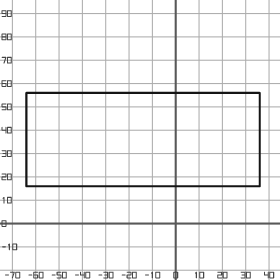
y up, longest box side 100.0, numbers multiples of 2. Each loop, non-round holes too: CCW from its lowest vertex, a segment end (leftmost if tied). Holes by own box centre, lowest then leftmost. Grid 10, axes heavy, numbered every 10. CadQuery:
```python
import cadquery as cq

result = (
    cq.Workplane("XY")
    .moveTo(-64.0, 16.0)
    .lineTo(36.0, 16.0)
    .lineTo(36.0, 56.0)
    .lineTo(-64.0, 56.0)
    .close()
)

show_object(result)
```